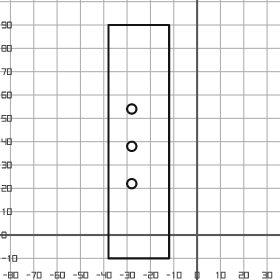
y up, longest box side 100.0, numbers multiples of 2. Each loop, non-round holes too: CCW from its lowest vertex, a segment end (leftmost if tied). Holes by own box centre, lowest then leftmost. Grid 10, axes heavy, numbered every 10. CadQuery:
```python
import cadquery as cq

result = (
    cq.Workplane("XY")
    .moveTo(-38.0, -10.0)
    .lineTo(-12.0, -10.0)
    .lineTo(-12.0, 90.0)
    .lineTo(-38.0, 90.0)
    .close()
    .moveTo(-28.0, 22.0)
    .circle(2.0)
    .moveTo(-28.0, 38.0)
    .circle(2.0)
    .moveTo(-28.0, 54.0)
    .circle(2.0)
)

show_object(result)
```